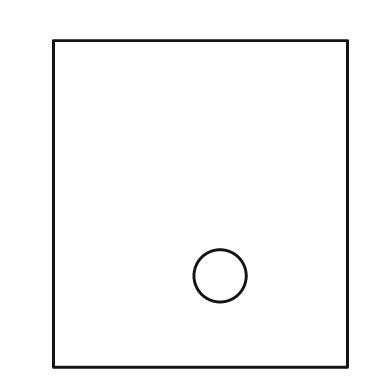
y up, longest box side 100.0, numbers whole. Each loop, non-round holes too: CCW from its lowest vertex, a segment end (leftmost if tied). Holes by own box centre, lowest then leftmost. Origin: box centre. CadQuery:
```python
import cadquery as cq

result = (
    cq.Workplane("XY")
    .moveTo(-45.0, -50.0)
    .lineTo(45.0, -50.0)
    .lineTo(45.0, 50.0)
    .lineTo(-45.0, 50.0)
    .close()
    .moveTo(6.0, -22.0)
    .circle(8.0)
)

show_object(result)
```